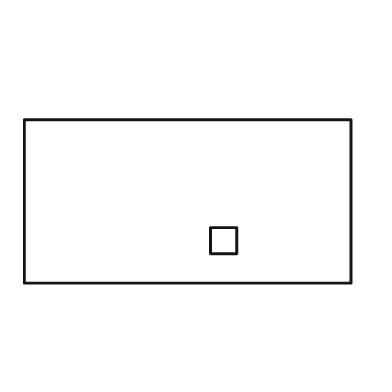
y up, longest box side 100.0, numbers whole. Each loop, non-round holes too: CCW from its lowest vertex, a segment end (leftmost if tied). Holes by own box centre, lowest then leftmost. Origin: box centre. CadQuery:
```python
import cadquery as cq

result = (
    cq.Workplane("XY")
    .moveTo(-50.0, -25.0)
    .lineTo(50.0, -25.0)
    .lineTo(50.0, 25.0)
    .lineTo(-50.0, 25.0)
    .close()
    .moveTo(7.0, -16.0)
    .lineTo(15.0, -16.0)
    .lineTo(15.0, -8.0)
    .lineTo(7.0, -8.0)
    .close()
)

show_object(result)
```